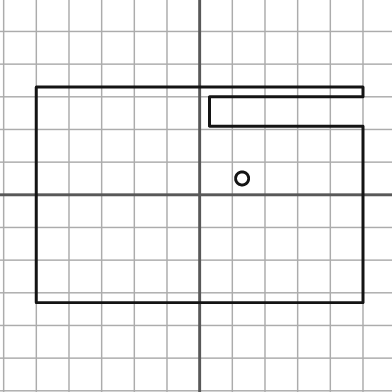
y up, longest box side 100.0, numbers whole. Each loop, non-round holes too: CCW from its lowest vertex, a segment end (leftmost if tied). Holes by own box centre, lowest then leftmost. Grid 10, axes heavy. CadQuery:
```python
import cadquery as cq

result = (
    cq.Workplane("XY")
    .moveTo(-50.0, -33.0)
    .lineTo(50.0, -33.0)
    .lineTo(50.0, 21.0)
    .lineTo(3.0, 21.0)
    .lineTo(3.0, 30.0)
    .lineTo(50.0, 30.0)
    .lineTo(50.0, 33.0)
    .lineTo(-50.0, 33.0)
    .close()
    .moveTo(13.0, 5.0)
    .circle(2.0)
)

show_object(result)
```